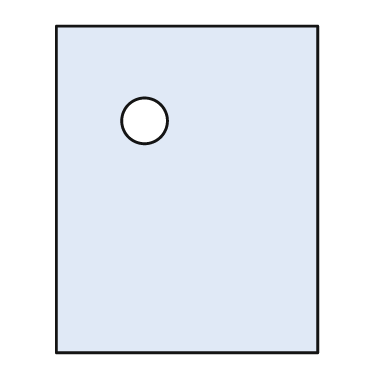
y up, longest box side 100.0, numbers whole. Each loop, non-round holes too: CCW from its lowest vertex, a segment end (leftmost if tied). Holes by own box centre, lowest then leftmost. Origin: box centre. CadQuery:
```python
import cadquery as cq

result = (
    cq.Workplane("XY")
    .moveTo(-40.0, -50.0)
    .lineTo(40.0, -50.0)
    .lineTo(40.0, 50.0)
    .lineTo(-40.0, 50.0)
    .close()
    .moveTo(-13.0, 21.0)
    .circle(7.0)
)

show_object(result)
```